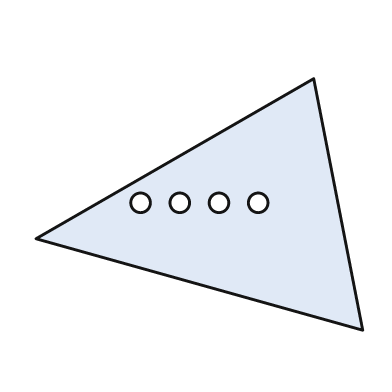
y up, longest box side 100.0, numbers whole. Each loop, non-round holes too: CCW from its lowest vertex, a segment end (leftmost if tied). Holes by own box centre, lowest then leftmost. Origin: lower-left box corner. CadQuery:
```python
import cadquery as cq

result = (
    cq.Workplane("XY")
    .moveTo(100.0, 0.0)
    .lineTo(85.0, 77.0)
    .lineTo(0.0, 28.0)
    .close()
    .moveTo(32.0, 39.0)
    .circle(3.0)
    .moveTo(44.0, 39.0)
    .circle(3.0)
    .moveTo(56.0, 39.0)
    .circle(3.0)
    .moveTo(68.0, 39.0)
    .circle(3.0)
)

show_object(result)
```